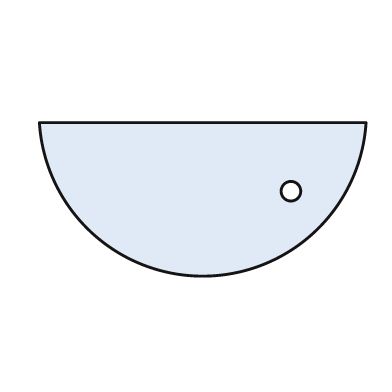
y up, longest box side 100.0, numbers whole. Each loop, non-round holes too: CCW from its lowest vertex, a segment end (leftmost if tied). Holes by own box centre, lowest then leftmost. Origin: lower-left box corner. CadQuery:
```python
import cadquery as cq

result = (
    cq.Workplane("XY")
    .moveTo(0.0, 47.0)
    .threePointArc((50.0, 0.0), (100.0, 47.0))
    .close()
    .moveTo(77.0, 26.0)
    .circle(3.0)
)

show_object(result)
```